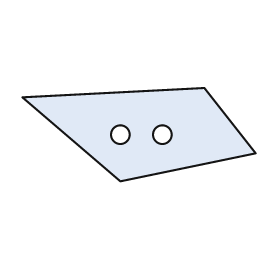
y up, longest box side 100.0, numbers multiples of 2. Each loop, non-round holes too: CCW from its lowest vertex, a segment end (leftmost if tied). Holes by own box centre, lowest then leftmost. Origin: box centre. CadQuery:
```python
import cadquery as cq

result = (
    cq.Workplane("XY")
    .moveTo(-8.0, -20.0)
    .lineTo(50.0, -8.0)
    .lineTo(28.0, 20.0)
    .lineTo(-50.0, 16.0)
    .close()
    .moveTo(-8.0, 0.0)
    .circle(4.0)
    .moveTo(10.0, 0.0)
    .circle(4.0)
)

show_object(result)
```